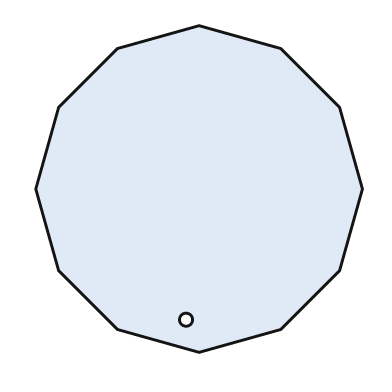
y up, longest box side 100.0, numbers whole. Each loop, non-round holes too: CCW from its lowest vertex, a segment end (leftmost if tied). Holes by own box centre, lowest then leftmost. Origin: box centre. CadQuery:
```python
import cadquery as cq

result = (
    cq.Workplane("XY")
    .moveTo(0.0, -50.0)
    .lineTo(25.0, -43.0)
    .lineTo(43.0, -25.0)
    .lineTo(50.0, 0.0)
    .lineTo(43.0, 25.0)
    .lineTo(25.0, 43.0)
    .lineTo(0.0, 50.0)
    .lineTo(-25.0, 43.0)
    .lineTo(-43.0, 25.0)
    .lineTo(-50.0, 0.0)
    .lineTo(-43.0, -25.0)
    .lineTo(-25.0, -43.0)
    .close()
    .moveTo(-4.0, -40.0)
    .circle(2.0)
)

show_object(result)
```